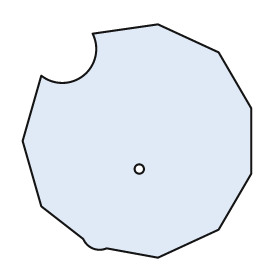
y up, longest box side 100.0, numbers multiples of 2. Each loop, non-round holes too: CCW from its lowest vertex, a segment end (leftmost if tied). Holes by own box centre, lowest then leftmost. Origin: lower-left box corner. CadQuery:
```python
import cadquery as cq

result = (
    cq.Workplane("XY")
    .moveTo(58.0, 0.0)
    .lineTo(84.0, 12.0)
    .lineTo(98.0, 36.0)
    .lineTo(98.0, 64.0)
    .lineTo(84.0, 88.0)
    .lineTo(58.0, 100.0)
    .lineTo(30.0, 96.0)
    .threePointArc((26.0, 78.0), (8.0, 78.0))
    .lineTo(0.0, 50.0)
    .lineTo(8.0, 22.0)
    .lineTo(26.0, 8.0)
    .threePointArc((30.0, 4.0), (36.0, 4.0))
    .close()
    .moveTo(50.0, 38.0)
    .circle(2.0)
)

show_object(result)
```